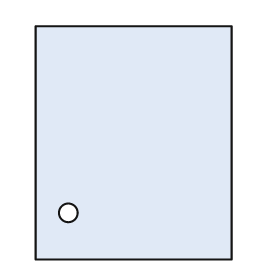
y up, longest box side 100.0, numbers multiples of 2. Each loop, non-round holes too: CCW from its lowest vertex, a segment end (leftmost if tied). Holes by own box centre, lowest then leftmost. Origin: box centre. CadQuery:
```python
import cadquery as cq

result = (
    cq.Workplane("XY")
    .moveTo(-42.0, -50.0)
    .lineTo(42.0, -50.0)
    .lineTo(42.0, 50.0)
    .lineTo(-42.0, 50.0)
    .close()
    .moveTo(-28.0, -30.0)
    .circle(4.0)
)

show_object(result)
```